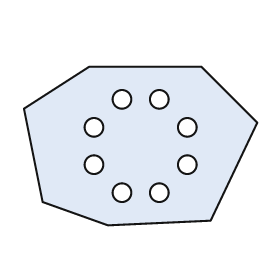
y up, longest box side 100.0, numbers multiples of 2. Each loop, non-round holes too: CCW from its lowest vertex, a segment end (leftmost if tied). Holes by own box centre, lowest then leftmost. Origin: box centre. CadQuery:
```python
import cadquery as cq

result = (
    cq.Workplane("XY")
    .moveTo(-14.0, -34.0)
    .lineTo(30.0, -32.0)
    .lineTo(50.0, 10.0)
    .lineTo(26.0, 34.0)
    .lineTo(-22.0, 34.0)
    .lineTo(-50.0, 16.0)
    .lineTo(-42.0, -24.0)
    .close()
    .moveTo(-8.0, -20.0)
    .circle(4.0)
    .moveTo(8.0, -20.0)
    .circle(4.0)
    .moveTo(-20.0, -8.0)
    .circle(4.0)
    .moveTo(20.0, -8.0)
    .circle(4.0)
    .moveTo(-20.0, 8.0)
    .circle(4.0)
    .moveTo(20.0, 8.0)
    .circle(4.0)
    .moveTo(-8.0, 20.0)
    .circle(4.0)
    .moveTo(8.0, 20.0)
    .circle(4.0)
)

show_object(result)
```